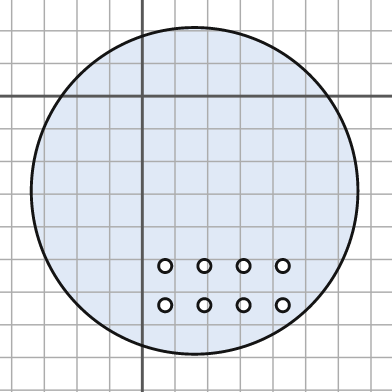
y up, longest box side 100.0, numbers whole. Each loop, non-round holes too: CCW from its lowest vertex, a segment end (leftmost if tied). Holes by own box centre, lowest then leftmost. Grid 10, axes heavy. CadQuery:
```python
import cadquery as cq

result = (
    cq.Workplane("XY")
    .moveTo(16.0, -29.0)
    .circle(50.0)
    .moveTo(7.0, -64.0)
    .circle(2.0)
    .moveTo(19.0, -64.0)
    .circle(2.0)
    .moveTo(31.0, -64.0)
    .circle(2.0)
    .moveTo(43.0, -64.0)
    .circle(2.0)
    .moveTo(7.0, -52.0)
    .circle(2.0)
    .moveTo(19.0, -52.0)
    .circle(2.0)
    .moveTo(31.0, -52.0)
    .circle(2.0)
    .moveTo(43.0, -52.0)
    .circle(2.0)
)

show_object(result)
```